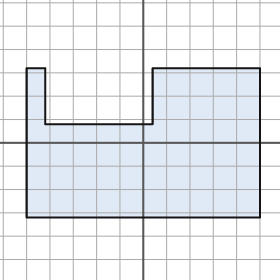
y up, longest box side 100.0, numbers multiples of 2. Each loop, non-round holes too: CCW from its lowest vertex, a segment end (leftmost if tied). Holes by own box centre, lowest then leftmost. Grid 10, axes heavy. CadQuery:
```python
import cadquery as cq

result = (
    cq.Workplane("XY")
    .moveTo(-50.0, -32.0)
    .lineTo(50.0, -32.0)
    .lineTo(50.0, 32.0)
    .lineTo(4.0, 32.0)
    .lineTo(4.0, 8.0)
    .lineTo(-42.0, 8.0)
    .lineTo(-42.0, 32.0)
    .lineTo(-50.0, 32.0)
    .close()
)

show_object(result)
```